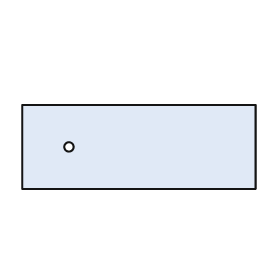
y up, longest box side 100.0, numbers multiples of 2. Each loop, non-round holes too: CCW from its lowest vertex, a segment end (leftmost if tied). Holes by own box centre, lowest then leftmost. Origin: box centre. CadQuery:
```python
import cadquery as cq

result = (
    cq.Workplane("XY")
    .moveTo(-50.0, -18.0)
    .lineTo(50.0, -18.0)
    .lineTo(50.0, 18.0)
    .lineTo(-50.0, 18.0)
    .close()
    .moveTo(-30.0, 0.0)
    .circle(2.0)
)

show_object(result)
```